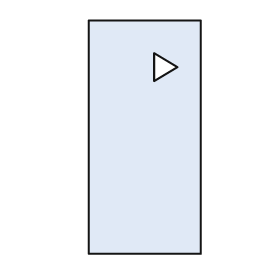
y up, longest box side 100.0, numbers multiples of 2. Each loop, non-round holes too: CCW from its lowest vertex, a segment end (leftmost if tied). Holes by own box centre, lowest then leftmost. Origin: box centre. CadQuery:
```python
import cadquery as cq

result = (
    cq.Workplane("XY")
    .moveTo(-24.0, -50.0)
    .lineTo(24.0, -50.0)
    .lineTo(24.0, 50.0)
    .lineTo(-24.0, 50.0)
    .close()
    .moveTo(4.0, 24.0)
    .lineTo(14.0, 30.0)
    .lineTo(4.0, 36.0)
    .close()
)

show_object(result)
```